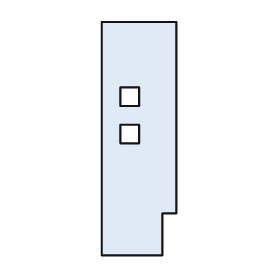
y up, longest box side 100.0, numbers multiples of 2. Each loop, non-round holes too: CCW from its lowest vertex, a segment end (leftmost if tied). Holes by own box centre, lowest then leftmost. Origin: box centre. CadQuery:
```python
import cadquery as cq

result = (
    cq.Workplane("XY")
    .moveTo(-16.0, -50.0)
    .lineTo(10.0, -50.0)
    .lineTo(10.0, -32.0)
    .lineTo(16.0, -32.0)
    .lineTo(16.0, 50.0)
    .lineTo(-16.0, 50.0)
    .close()
    .moveTo(-8.0, -2.0)
    .lineTo(0.0, -2.0)
    .lineTo(0.0, 6.0)
    .lineTo(-8.0, 6.0)
    .close()
    .moveTo(-8.0, 14.0)
    .lineTo(0.0, 14.0)
    .lineTo(0.0, 22.0)
    .lineTo(-8.0, 22.0)
    .close()
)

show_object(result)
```